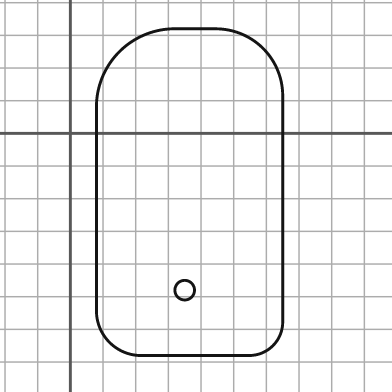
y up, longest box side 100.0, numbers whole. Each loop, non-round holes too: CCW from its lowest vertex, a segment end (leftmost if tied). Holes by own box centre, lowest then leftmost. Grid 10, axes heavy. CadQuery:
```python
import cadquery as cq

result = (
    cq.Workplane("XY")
    .moveTo(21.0, -68.0)
    .lineTo(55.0, -68.0)
    .threePointArc((62.0, -65.0), (65.0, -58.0))
    .lineTo(65.0, 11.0)
    .threePointArc((59.0, 26.0), (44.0, 32.0))
    .lineTo(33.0, 32.0)
    .threePointArc((15.0, 25.0), (8.0, 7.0))
    .lineTo(8.0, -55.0)
    .threePointArc((12.0, -64.0), (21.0, -68.0))
    .close()
    .moveTo(35.0, -48.0)
    .circle(3.0)
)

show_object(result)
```